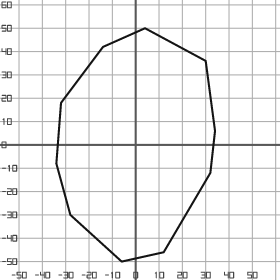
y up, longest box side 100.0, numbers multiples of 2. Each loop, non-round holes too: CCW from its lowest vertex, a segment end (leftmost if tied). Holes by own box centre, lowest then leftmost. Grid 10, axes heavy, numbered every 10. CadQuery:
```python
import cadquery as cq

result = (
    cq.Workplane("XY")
    .moveTo(-6.0, -50.0)
    .lineTo(12.0, -46.0)
    .lineTo(32.0, -12.0)
    .lineTo(34.0, 6.0)
    .lineTo(30.0, 36.0)
    .lineTo(4.0, 50.0)
    .lineTo(-14.0, 42.0)
    .lineTo(-32.0, 18.0)
    .lineTo(-34.0, -8.0)
    .lineTo(-28.0, -30.0)
    .close()
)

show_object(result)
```